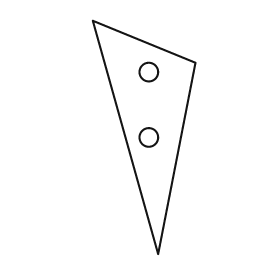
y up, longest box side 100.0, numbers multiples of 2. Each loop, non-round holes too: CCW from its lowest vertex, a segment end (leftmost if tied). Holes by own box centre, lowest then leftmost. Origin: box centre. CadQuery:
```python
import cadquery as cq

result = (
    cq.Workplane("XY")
    .moveTo(6.0, -50.0)
    .lineTo(22.0, 32.0)
    .lineTo(-22.0, 50.0)
    .close()
    .moveTo(2.0, 0.0)
    .circle(4.0)
    .moveTo(2.0, 28.0)
    .circle(4.0)
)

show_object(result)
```